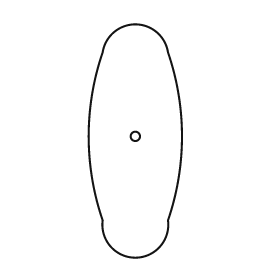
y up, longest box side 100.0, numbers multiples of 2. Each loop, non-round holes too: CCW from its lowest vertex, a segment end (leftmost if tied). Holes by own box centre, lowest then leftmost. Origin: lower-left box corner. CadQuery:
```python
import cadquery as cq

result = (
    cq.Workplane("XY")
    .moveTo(6.0, 16.0)
    .threePointArc((20.0, 0.0), (34.0, 16.0))
    .threePointArc((40.0, 52.0), (34.0, 88.0))
    .threePointArc((20.0, 100.0), (6.0, 88.0))
    .threePointArc((0.0, 52.0), (6.0, 16.0))
    .close()
    .moveTo(20.0, 52.0)
    .circle(2.0)
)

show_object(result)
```